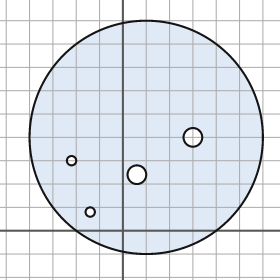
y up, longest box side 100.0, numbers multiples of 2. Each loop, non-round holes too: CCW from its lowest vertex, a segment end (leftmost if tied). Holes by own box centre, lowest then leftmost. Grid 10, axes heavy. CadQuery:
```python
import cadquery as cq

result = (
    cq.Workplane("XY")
    .moveTo(10.0, 40.0)
    .circle(50.0)
    .moveTo(-14.0, 8.0)
    .circle(2.0)
    .moveTo(6.0, 24.0)
    .circle(4.0)
    .moveTo(-22.0, 30.0)
    .circle(2.0)
    .moveTo(30.0, 40.0)
    .circle(4.0)
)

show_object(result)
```